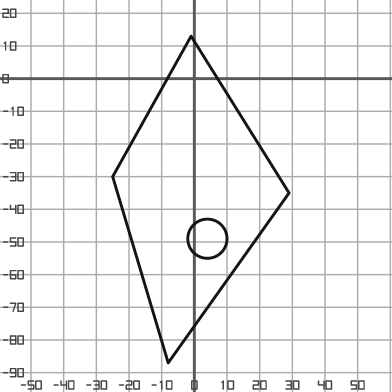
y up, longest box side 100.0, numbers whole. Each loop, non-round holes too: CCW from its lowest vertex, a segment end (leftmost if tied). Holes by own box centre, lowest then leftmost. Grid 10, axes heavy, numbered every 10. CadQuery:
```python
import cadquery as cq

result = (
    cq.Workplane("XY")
    .moveTo(-8.0, -87.0)
    .lineTo(29.0, -35.0)
    .lineTo(-1.0, 13.0)
    .lineTo(-25.0, -30.0)
    .close()
    .moveTo(4.0, -49.0)
    .circle(6.0)
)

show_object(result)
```